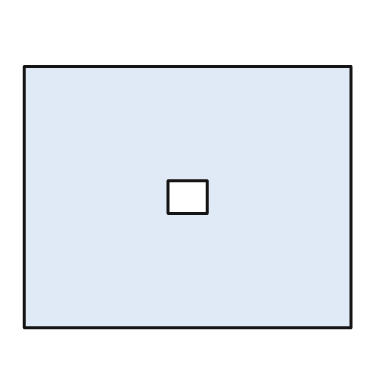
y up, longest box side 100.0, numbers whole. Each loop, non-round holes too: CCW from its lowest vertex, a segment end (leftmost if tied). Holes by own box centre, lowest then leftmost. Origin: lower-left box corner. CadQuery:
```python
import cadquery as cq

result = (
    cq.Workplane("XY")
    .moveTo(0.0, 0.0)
    .lineTo(100.0, 0.0)
    .lineTo(100.0, 80.0)
    .lineTo(0.0, 80.0)
    .close()
    .moveTo(44.0, 35.0)
    .lineTo(56.0, 35.0)
    .lineTo(56.0, 45.0)
    .lineTo(44.0, 45.0)
    .close()
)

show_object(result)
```